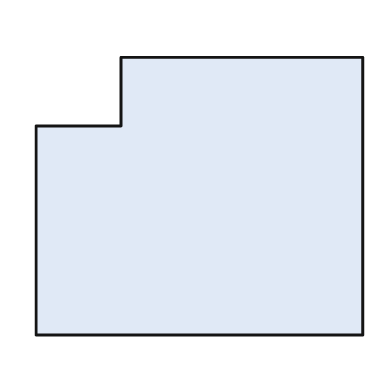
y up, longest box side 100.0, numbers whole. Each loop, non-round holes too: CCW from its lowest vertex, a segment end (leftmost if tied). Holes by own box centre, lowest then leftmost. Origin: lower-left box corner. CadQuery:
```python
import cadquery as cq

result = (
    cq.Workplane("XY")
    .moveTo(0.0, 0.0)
    .lineTo(100.0, 0.0)
    .lineTo(100.0, 85.0)
    .lineTo(26.0, 85.0)
    .lineTo(26.0, 64.0)
    .lineTo(0.0, 64.0)
    .close()
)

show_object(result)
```